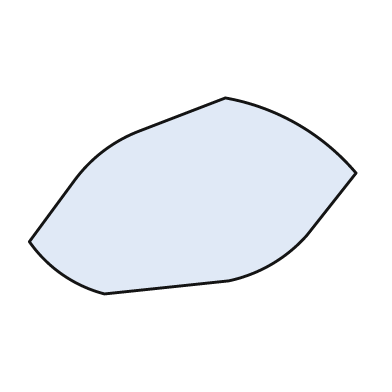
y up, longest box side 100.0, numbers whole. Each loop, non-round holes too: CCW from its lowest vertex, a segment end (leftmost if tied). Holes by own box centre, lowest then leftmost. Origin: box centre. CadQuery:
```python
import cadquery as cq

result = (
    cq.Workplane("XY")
    .moveTo(-27.0, -30.0)
    .lineTo(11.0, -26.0)
    .threePointArc((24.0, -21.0), (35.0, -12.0))
    .lineTo(50.0, 7.0)
    .threePointArc((32.0, 22.0), (10.0, 30.0))
    .lineTo(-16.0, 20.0)
    .threePointArc((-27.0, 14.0), (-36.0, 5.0))
    .lineTo(-50.0, -14.0)
    .threePointArc((-40.0, -24.0), (-27.0, -30.0))
    .close()
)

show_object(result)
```